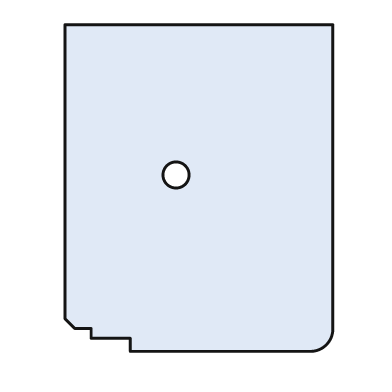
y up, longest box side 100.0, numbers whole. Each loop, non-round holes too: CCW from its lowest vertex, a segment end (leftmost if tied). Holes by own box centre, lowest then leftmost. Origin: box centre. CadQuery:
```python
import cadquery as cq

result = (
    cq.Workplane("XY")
    .moveTo(-21.0, -50.0)
    .lineTo(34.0, -50.0)
    .threePointArc((39.0, -48.0), (41.0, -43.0))
    .lineTo(41.0, 50.0)
    .lineTo(-41.0, 50.0)
    .lineTo(-41.0, -40.0)
    .lineTo(-38.0, -43.0)
    .lineTo(-33.0, -43.0)
    .lineTo(-33.0, -46.0)
    .lineTo(-21.0, -46.0)
    .close()
    .moveTo(-7.0, 4.0)
    .circle(4.0)
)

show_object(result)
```